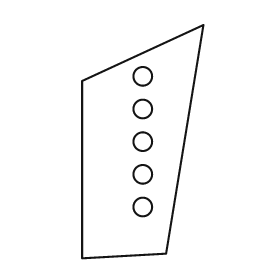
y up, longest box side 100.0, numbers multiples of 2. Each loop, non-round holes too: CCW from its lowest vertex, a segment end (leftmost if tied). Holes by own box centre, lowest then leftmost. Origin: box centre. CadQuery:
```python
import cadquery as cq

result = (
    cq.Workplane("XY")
    .moveTo(-26.0, -50.0)
    .lineTo(10.0, -48.0)
    .lineTo(26.0, 50.0)
    .lineTo(-26.0, 26.0)
    .close()
    .moveTo(0.0, -28.0)
    .circle(4.0)
    .moveTo(0.0, -14.0)
    .circle(4.0)
    .moveTo(0.0, 0.0)
    .circle(4.0)
    .moveTo(0.0, 14.0)
    .circle(4.0)
    .moveTo(0.0, 28.0)
    .circle(4.0)
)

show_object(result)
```